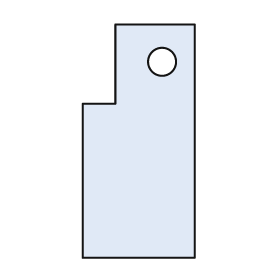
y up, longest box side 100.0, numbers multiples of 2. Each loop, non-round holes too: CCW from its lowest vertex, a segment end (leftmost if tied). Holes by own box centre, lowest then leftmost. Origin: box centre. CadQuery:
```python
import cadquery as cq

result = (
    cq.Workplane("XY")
    .moveTo(-24.0, -50.0)
    .lineTo(24.0, -50.0)
    .lineTo(24.0, 50.0)
    .lineTo(-10.0, 50.0)
    .lineTo(-10.0, 16.0)
    .lineTo(-24.0, 16.0)
    .close()
    .moveTo(10.0, 34.0)
    .circle(6.0)
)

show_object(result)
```